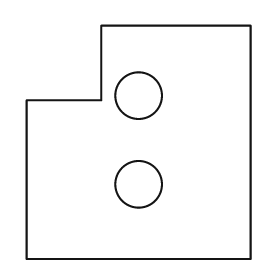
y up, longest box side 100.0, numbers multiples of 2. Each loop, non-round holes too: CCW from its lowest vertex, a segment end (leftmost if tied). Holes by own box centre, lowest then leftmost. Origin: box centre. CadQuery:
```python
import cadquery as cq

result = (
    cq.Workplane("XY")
    .moveTo(-48.0, -50.0)
    .lineTo(48.0, -50.0)
    .lineTo(48.0, 50.0)
    .lineTo(-16.0, 50.0)
    .lineTo(-16.0, 18.0)
    .lineTo(-48.0, 18.0)
    .close()
    .moveTo(0.0, -18.0)
    .circle(10.0)
    .moveTo(0.0, 20.0)
    .circle(10.0)
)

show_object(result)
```